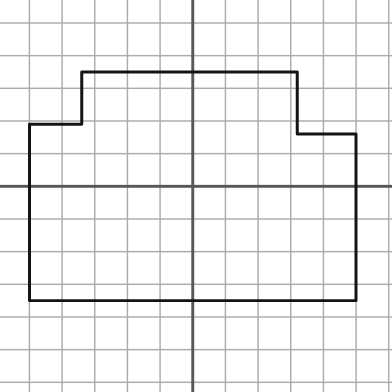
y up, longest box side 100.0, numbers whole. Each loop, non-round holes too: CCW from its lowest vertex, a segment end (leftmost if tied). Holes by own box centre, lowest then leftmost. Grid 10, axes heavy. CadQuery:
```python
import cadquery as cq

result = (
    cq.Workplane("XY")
    .moveTo(-50.0, -35.0)
    .lineTo(50.0, -35.0)
    .lineTo(50.0, 16.0)
    .lineTo(32.0, 16.0)
    .lineTo(32.0, 35.0)
    .lineTo(-34.0, 35.0)
    .lineTo(-34.0, 19.0)
    .lineTo(-50.0, 19.0)
    .close()
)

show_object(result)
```